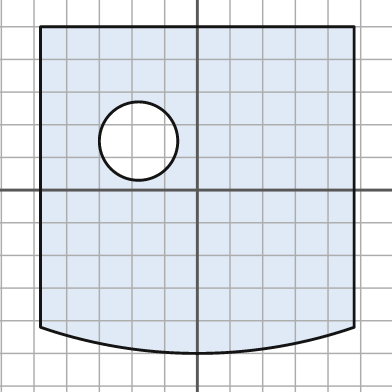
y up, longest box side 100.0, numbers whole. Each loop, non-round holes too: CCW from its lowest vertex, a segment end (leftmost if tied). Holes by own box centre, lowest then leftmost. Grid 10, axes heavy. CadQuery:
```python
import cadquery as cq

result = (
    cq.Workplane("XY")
    .moveTo(-48.0, -42.0)
    .threePointArc((0.0, -50.0), (48.0, -42.0))
    .lineTo(48.0, 50.0)
    .lineTo(-48.0, 50.0)
    .close()
    .moveTo(-18.0, 15.0)
    .circle(12.0)
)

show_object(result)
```